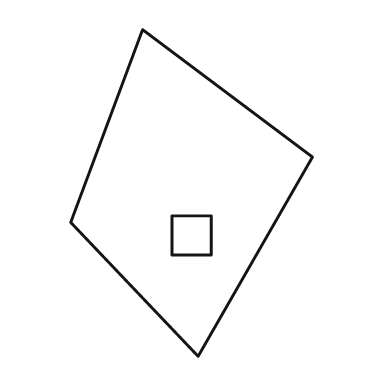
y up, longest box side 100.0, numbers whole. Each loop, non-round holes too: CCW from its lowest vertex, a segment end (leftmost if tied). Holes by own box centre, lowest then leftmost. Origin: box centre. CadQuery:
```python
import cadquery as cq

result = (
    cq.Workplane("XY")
    .moveTo(2.0, -50.0)
    .lineTo(37.0, 11.0)
    .lineTo(-15.0, 50.0)
    .lineTo(-37.0, -9.0)
    .close()
    .moveTo(-6.0, -19.0)
    .lineTo(6.0, -19.0)
    .lineTo(6.0, -7.0)
    .lineTo(-6.0, -7.0)
    .close()
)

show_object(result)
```